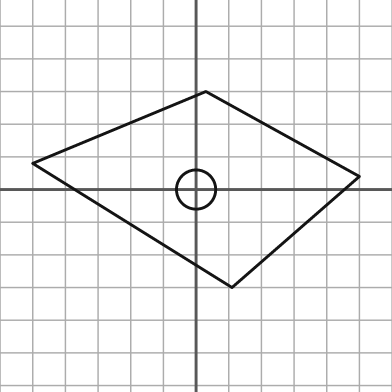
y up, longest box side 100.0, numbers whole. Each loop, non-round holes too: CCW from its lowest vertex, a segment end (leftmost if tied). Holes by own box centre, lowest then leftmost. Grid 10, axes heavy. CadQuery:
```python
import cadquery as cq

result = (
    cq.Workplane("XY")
    .moveTo(11.0, -30.0)
    .lineTo(50.0, 4.0)
    .lineTo(3.0, 30.0)
    .lineTo(-50.0, 8.0)
    .close()
    .moveTo(0.0, 0.0)
    .circle(6.0)
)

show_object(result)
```